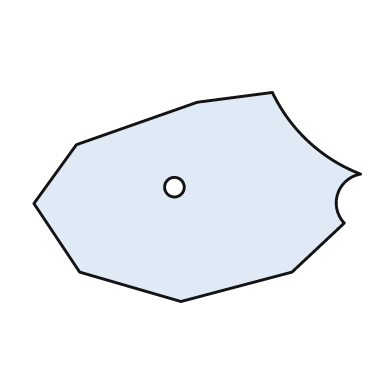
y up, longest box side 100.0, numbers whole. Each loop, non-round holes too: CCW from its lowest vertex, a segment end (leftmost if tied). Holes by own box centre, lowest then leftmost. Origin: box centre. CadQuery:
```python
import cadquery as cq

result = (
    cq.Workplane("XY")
    .moveTo(-5.0, -32.0)
    .lineTo(29.0, -23.0)
    .lineTo(45.0, -8.0)
    .threePointArc((43.0, 1.0), (50.0, 7.0))
    .threePointArc((34.0, 17.0), (23.0, 32.0))
    .lineTo(0.0, 29.0)
    .lineTo(-37.0, 16.0)
    .lineTo(-50.0, -2.0)
    .lineTo(-36.0, -23.0)
    .close()
    .moveTo(-7.0, 3.0)
    .circle(3.0)
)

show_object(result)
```